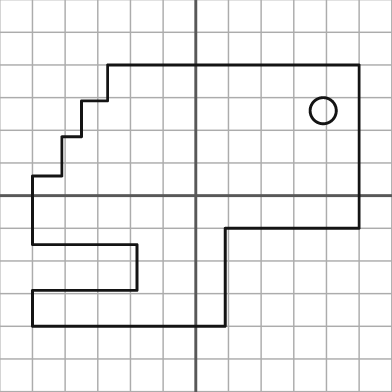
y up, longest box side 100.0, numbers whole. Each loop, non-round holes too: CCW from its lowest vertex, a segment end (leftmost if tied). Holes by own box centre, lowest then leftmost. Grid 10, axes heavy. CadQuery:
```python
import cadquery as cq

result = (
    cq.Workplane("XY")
    .moveTo(-50.0, -40.0)
    .lineTo(9.0, -40.0)
    .lineTo(9.0, -10.0)
    .lineTo(50.0, -10.0)
    .lineTo(50.0, 40.0)
    .lineTo(-27.0, 40.0)
    .lineTo(-27.0, 29.0)
    .lineTo(-35.0, 29.0)
    .lineTo(-35.0, 18.0)
    .lineTo(-41.0, 18.0)
    .lineTo(-41.0, 6.0)
    .lineTo(-50.0, 6.0)
    .lineTo(-50.0, -15.0)
    .lineTo(-18.0, -15.0)
    .lineTo(-18.0, -29.0)
    .lineTo(-50.0, -29.0)
    .close()
    .moveTo(39.0, 26.0)
    .circle(4.0)
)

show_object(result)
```